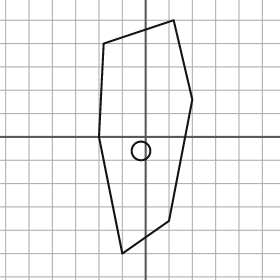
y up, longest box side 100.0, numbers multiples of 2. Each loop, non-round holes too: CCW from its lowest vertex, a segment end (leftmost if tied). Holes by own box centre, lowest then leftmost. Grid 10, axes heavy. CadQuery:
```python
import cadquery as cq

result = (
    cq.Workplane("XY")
    .moveTo(-10.0, -50.0)
    .lineTo(10.0, -36.0)
    .lineTo(20.0, 16.0)
    .lineTo(12.0, 50.0)
    .lineTo(-18.0, 40.0)
    .lineTo(-20.0, 0.0)
    .close()
    .moveTo(-2.0, -6.0)
    .circle(4.0)
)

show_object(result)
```